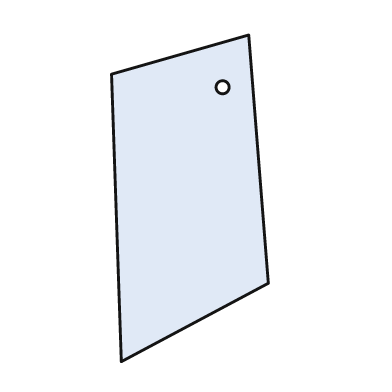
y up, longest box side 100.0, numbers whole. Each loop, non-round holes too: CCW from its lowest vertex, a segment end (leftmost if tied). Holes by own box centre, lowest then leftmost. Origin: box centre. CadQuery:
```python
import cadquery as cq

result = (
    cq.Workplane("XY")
    .moveTo(-21.0, -50.0)
    .lineTo(24.0, -26.0)
    .lineTo(18.0, 50.0)
    .lineTo(-24.0, 38.0)
    .close()
    .moveTo(10.0, 34.0)
    .circle(2.0)
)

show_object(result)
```